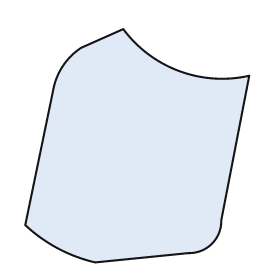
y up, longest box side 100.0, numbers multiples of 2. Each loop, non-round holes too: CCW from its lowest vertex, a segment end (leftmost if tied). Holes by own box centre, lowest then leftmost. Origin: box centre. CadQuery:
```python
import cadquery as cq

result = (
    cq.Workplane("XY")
    .moveTo(-18.0, -50.0)
    .lineTo(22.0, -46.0)
    .threePointArc((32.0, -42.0), (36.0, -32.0))
    .lineTo(48.0, 30.0)
    .threePointArc((18.0, 32.0), (-6.0, 50.0))
    .lineTo(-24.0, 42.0)
    .threePointArc((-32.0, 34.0), (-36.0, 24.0))
    .lineTo(-48.0, -34.0)
    .threePointArc((-34.0, -44.0), (-18.0, -50.0))
    .close()
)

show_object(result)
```